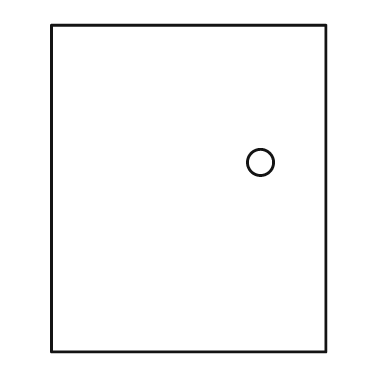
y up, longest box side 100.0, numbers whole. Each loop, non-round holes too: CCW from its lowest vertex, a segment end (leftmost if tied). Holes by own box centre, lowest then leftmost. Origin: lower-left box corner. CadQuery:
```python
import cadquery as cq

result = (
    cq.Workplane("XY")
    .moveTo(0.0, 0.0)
    .lineTo(84.0, 0.0)
    .lineTo(84.0, 100.0)
    .lineTo(0.0, 100.0)
    .close()
    .moveTo(64.0, 58.0)
    .circle(4.0)
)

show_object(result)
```